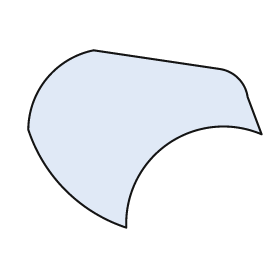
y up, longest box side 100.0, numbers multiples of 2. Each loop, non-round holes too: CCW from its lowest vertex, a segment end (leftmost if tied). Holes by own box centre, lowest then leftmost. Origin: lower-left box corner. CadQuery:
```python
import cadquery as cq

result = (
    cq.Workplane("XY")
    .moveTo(42.0, 0.0)
    .threePointArc((60.0, 36.0), (100.0, 40.0))
    .lineTo(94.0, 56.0)
    .threePointArc((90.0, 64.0), (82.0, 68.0))
    .lineTo(28.0, 76.0)
    .threePointArc((8.0, 64.0), (0.0, 42.0))
    .threePointArc((16.0, 16.0), (42.0, 0.0))
    .close()
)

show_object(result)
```